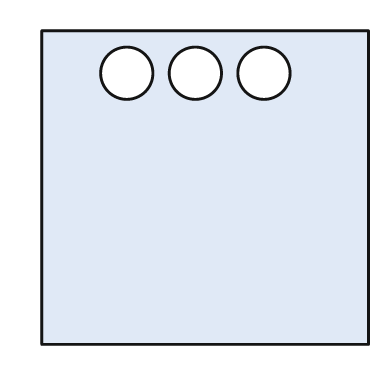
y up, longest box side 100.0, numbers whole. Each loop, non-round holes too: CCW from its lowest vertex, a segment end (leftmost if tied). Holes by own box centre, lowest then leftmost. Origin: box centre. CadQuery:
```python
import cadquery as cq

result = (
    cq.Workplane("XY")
    .moveTo(-50.0, -48.0)
    .lineTo(50.0, -48.0)
    .lineTo(50.0, 48.0)
    .lineTo(-50.0, 48.0)
    .close()
    .moveTo(-24.0, 35.0)
    .circle(8.0)
    .moveTo(-3.0, 35.0)
    .circle(8.0)
    .moveTo(18.0, 35.0)
    .circle(8.0)
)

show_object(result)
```